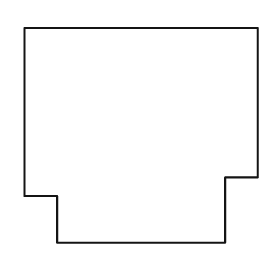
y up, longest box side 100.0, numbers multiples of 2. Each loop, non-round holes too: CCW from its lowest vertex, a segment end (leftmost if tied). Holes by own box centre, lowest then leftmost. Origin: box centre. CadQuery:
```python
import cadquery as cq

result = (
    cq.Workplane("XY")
    .moveTo(-36.0, -46.0)
    .lineTo(36.0, -46.0)
    .lineTo(36.0, -18.0)
    .lineTo(50.0, -18.0)
    .lineTo(50.0, 46.0)
    .lineTo(-50.0, 46.0)
    .lineTo(-50.0, -26.0)
    .lineTo(-36.0, -26.0)
    .close()
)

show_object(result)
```